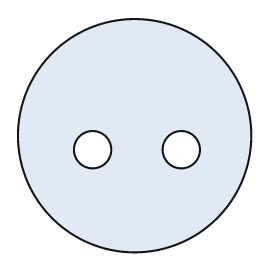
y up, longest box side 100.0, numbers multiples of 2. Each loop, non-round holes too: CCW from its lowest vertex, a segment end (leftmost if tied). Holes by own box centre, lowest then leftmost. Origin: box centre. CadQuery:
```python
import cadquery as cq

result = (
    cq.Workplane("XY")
    .moveTo(0.0, 0.0)
    .circle(50.0)
    .moveTo(-18.0, -6.0)
    .circle(8.0)
    .moveTo(20.0, -6.0)
    .circle(8.0)
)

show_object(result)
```